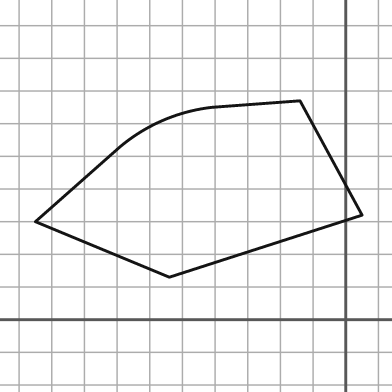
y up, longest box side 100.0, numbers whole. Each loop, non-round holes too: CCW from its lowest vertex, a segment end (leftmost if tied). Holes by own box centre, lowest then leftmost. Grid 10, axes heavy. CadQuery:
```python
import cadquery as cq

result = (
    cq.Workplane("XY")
    .moveTo(-54.0, 13.0)
    .lineTo(5.0, 32.0)
    .lineTo(-14.0, 67.0)
    .lineTo(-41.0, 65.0)
    .threePointArc((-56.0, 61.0), (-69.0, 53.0))
    .lineTo(-95.0, 30.0)
    .close()
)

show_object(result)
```